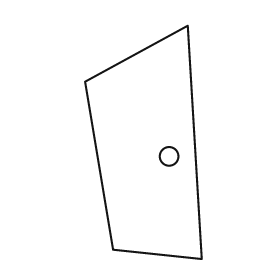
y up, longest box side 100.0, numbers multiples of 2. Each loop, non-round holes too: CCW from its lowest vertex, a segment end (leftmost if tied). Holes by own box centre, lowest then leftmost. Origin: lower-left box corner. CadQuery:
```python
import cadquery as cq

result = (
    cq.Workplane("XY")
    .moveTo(50.0, 0.0)
    .lineTo(44.0, 100.0)
    .lineTo(0.0, 76.0)
    .lineTo(12.0, 4.0)
    .close()
    .moveTo(36.0, 44.0)
    .circle(4.0)
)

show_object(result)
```